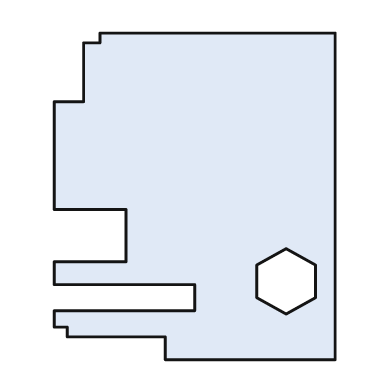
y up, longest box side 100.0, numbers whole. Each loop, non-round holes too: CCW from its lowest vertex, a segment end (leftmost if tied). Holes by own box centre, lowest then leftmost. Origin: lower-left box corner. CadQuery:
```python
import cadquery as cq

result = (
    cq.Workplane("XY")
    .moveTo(34.0, 0.0)
    .lineTo(86.0, 0.0)
    .lineTo(86.0, 100.0)
    .lineTo(14.0, 100.0)
    .lineTo(14.0, 97.0)
    .lineTo(9.0, 97.0)
    .lineTo(9.0, 79.0)
    .lineTo(0.0, 79.0)
    .lineTo(0.0, 46.0)
    .lineTo(22.0, 46.0)
    .lineTo(22.0, 30.0)
    .lineTo(0.0, 30.0)
    .lineTo(0.0, 23.0)
    .lineTo(43.0, 23.0)
    .lineTo(43.0, 15.0)
    .lineTo(0.0, 15.0)
    .lineTo(0.0, 10.0)
    .lineTo(4.0, 10.0)
    .lineTo(4.0, 7.0)
    .lineTo(34.0, 7.0)
    .close()
    .moveTo(71.0, 14.0)
    .lineTo(80.0, 19.0)
    .lineTo(80.0, 29.0)
    .lineTo(71.0, 34.0)
    .lineTo(62.0, 29.0)
    .lineTo(62.0, 19.0)
    .close()
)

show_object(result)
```